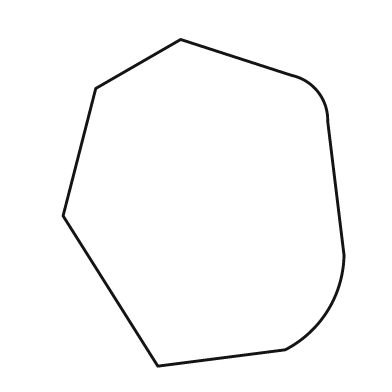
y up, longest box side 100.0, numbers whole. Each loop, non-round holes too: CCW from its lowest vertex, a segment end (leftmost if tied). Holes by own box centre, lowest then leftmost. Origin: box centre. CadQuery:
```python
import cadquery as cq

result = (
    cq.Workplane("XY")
    .moveTo(-14.0, -50.0)
    .lineTo(25.0, -45.0)
    .threePointArc((38.0, -33.0), (43.0, -16.0))
    .lineTo(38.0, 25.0)
    .threePointArc((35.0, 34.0), (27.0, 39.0))
    .lineTo(-7.0, 50.0)
    .lineTo(-33.0, 35.0)
    .lineTo(-43.0, -4.0)
    .close()
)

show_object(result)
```